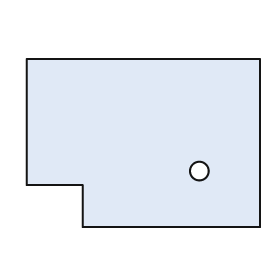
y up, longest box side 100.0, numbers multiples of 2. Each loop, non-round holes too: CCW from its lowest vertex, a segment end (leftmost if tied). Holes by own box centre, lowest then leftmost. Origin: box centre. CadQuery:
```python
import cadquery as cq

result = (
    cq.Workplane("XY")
    .moveTo(-26.0, -36.0)
    .lineTo(50.0, -36.0)
    .lineTo(50.0, 36.0)
    .lineTo(-50.0, 36.0)
    .lineTo(-50.0, -18.0)
    .lineTo(-26.0, -18.0)
    .close()
    .moveTo(24.0, -12.0)
    .circle(4.0)
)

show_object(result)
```